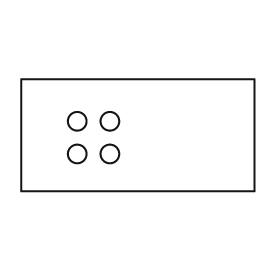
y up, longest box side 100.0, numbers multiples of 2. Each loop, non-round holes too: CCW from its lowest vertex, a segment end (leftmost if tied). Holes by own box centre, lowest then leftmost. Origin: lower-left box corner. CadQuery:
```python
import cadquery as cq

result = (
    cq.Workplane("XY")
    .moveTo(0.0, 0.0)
    .lineTo(100.0, 0.0)
    .lineTo(100.0, 48.0)
    .lineTo(0.0, 48.0)
    .close()
    .moveTo(24.0, 16.0)
    .circle(4.0)
    .moveTo(38.0, 16.0)
    .circle(4.0)
    .moveTo(24.0, 30.0)
    .circle(4.0)
    .moveTo(38.0, 30.0)
    .circle(4.0)
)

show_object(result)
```